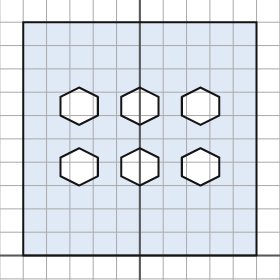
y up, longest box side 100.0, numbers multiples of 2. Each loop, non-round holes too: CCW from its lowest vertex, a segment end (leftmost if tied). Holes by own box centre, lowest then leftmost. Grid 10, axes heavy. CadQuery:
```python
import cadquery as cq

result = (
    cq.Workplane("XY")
    .moveTo(-50.0, 0.0)
    .lineTo(50.0, 0.0)
    .lineTo(50.0, 100.0)
    .lineTo(-50.0, 100.0)
    .close()
    .moveTo(-26.0, 30.0)
    .lineTo(-18.0, 34.0)
    .lineTo(-18.0, 42.0)
    .lineTo(-26.0, 46.0)
    .lineTo(-34.0, 42.0)
    .lineTo(-34.0, 34.0)
    .close()
    .moveTo(0.0, 30.0)
    .lineTo(8.0, 34.0)
    .lineTo(8.0, 42.0)
    .lineTo(0.0, 46.0)
    .lineTo(-8.0, 42.0)
    .lineTo(-8.0, 34.0)
    .close()
    .moveTo(26.0, 30.0)
    .lineTo(34.0, 34.0)
    .lineTo(34.0, 42.0)
    .lineTo(26.0, 46.0)
    .lineTo(18.0, 42.0)
    .lineTo(18.0, 34.0)
    .close()
    .moveTo(-26.0, 56.0)
    .lineTo(-18.0, 60.0)
    .lineTo(-18.0, 68.0)
    .lineTo(-26.0, 72.0)
    .lineTo(-34.0, 68.0)
    .lineTo(-34.0, 60.0)
    .close()
    .moveTo(0.0, 56.0)
    .lineTo(8.0, 60.0)
    .lineTo(8.0, 68.0)
    .lineTo(0.0, 72.0)
    .lineTo(-8.0, 68.0)
    .lineTo(-8.0, 60.0)
    .close()
    .moveTo(26.0, 56.0)
    .lineTo(34.0, 60.0)
    .lineTo(34.0, 68.0)
    .lineTo(26.0, 72.0)
    .lineTo(18.0, 68.0)
    .lineTo(18.0, 60.0)
    .close()
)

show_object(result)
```